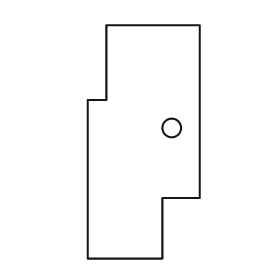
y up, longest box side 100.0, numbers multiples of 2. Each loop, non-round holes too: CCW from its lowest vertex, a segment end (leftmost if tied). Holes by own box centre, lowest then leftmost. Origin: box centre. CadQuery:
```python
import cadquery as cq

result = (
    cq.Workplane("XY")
    .moveTo(-24.0, -50.0)
    .lineTo(8.0, -50.0)
    .lineTo(8.0, -24.0)
    .lineTo(24.0, -24.0)
    .lineTo(24.0, 50.0)
    .lineTo(-16.0, 50.0)
    .lineTo(-16.0, 18.0)
    .lineTo(-24.0, 18.0)
    .close()
    .moveTo(12.0, 6.0)
    .circle(4.0)
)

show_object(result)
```